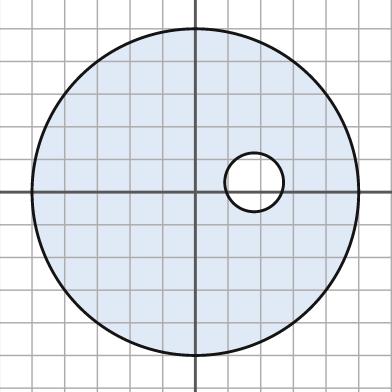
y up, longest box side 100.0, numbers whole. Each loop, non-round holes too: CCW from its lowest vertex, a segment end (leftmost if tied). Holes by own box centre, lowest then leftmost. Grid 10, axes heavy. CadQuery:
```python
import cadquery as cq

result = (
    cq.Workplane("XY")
    .moveTo(0.0, 0.0)
    .circle(50.0)
    .moveTo(18.0, 3.0)
    .circle(9.0)
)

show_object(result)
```